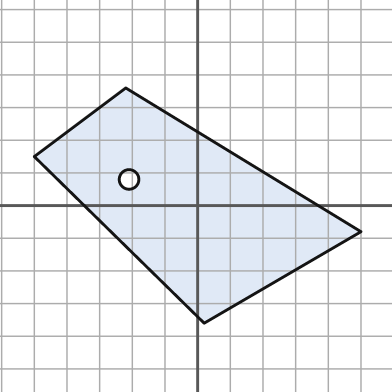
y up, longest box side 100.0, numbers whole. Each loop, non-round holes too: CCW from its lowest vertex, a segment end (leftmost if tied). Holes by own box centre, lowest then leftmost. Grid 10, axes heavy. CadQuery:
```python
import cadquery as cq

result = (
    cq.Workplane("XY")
    .moveTo(2.0, -36.0)
    .lineTo(50.0, -8.0)
    .lineTo(-22.0, 36.0)
    .lineTo(-50.0, 15.0)
    .close()
    .moveTo(-21.0, 8.0)
    .circle(3.0)
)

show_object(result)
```